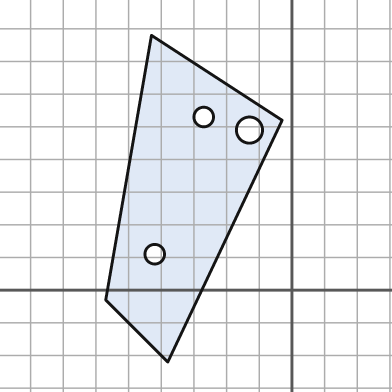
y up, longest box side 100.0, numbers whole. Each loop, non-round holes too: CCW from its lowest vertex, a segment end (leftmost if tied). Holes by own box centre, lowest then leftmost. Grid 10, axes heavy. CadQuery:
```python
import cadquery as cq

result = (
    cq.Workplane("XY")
    .moveTo(-38.0, -22.0)
    .lineTo(-3.0, 52.0)
    .lineTo(-43.0, 78.0)
    .lineTo(-57.0, -3.0)
    .close()
    .moveTo(-42.0, 11.0)
    .circle(3.0)
    .moveTo(-13.0, 49.0)
    .circle(4.0)
    .moveTo(-27.0, 53.0)
    .circle(3.0)
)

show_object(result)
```